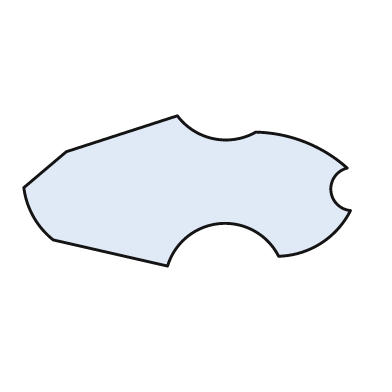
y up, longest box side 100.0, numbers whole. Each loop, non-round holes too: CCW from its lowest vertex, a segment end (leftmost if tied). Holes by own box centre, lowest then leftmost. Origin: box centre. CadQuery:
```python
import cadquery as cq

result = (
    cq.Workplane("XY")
    .moveTo(-6.0, -23.0)
    .threePointArc((10.0, -10.0), (28.0, -20.0))
    .threePointArc((41.0, -16.0), (50.0, -6.0))
    .threePointArc((44.0, 0.0), (49.0, 7.0))
    .threePointArc((36.0, 15.0), (21.0, 18.0))
    .threePointArc((8.0, 16.0), (-3.0, 23.0))
    .lineTo(-37.0, 12.0)
    .lineTo(-50.0, 1.0)
    .threePointArc((-47.0, -8.0), (-41.0, -15.0))
    .close()
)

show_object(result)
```